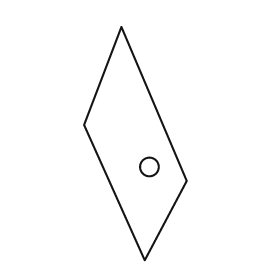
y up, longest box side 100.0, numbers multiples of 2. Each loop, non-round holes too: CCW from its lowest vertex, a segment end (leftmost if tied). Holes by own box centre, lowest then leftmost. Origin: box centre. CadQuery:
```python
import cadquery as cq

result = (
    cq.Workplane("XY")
    .moveTo(4.0, -50.0)
    .lineTo(22.0, -16.0)
    .lineTo(-6.0, 50.0)
    .lineTo(-22.0, 8.0)
    .close()
    .moveTo(6.0, -10.0)
    .circle(4.0)
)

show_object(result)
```